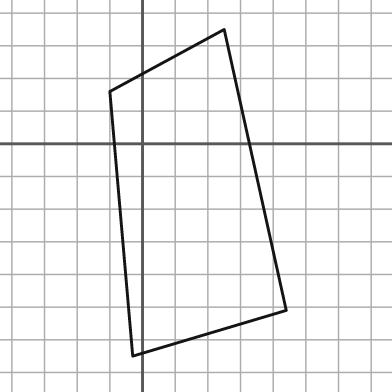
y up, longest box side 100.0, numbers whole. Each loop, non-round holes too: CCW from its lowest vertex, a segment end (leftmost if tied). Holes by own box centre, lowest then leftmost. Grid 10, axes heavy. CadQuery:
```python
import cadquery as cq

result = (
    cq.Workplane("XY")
    .moveTo(-3.0, -65.0)
    .lineTo(44.0, -51.0)
    .lineTo(25.0, 35.0)
    .lineTo(-10.0, 16.0)
    .close()
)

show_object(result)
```